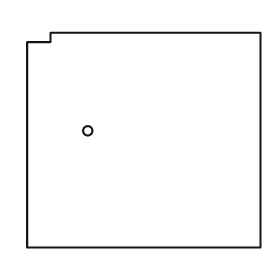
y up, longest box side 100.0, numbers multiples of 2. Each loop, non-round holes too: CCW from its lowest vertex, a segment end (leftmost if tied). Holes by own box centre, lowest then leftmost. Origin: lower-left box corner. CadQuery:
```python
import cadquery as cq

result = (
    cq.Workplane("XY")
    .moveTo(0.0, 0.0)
    .lineTo(100.0, 0.0)
    .lineTo(100.0, 92.0)
    .lineTo(10.0, 92.0)
    .lineTo(10.0, 88.0)
    .lineTo(0.0, 88.0)
    .close()
    .moveTo(26.0, 50.0)
    .circle(2.0)
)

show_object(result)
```